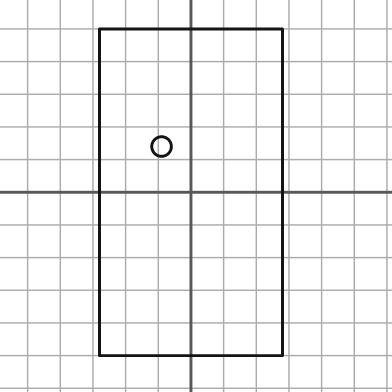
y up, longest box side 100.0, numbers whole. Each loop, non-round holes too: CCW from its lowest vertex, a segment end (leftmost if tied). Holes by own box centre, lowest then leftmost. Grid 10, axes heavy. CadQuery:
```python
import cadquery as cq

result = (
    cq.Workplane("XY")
    .moveTo(-28.0, -50.0)
    .lineTo(28.0, -50.0)
    .lineTo(28.0, 50.0)
    .lineTo(-28.0, 50.0)
    .close()
    .moveTo(-9.0, 14.0)
    .circle(3.0)
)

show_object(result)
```